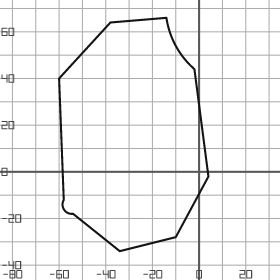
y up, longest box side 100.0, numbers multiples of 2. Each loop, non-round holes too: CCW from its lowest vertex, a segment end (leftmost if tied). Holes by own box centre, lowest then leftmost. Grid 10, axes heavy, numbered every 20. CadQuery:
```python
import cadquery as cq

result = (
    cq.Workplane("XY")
    .moveTo(-34.0, -34.0)
    .lineTo(-10.0, -28.0)
    .lineTo(4.0, -2.0)
    .lineTo(-2.0, 44.0)
    .threePointArc((-10.0, 54.0), (-14.0, 66.0))
    .lineTo(-38.0, 64.0)
    .lineTo(-60.0, 40.0)
    .lineTo(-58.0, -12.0)
    .threePointArc((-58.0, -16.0), (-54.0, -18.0))
    .close()
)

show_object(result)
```